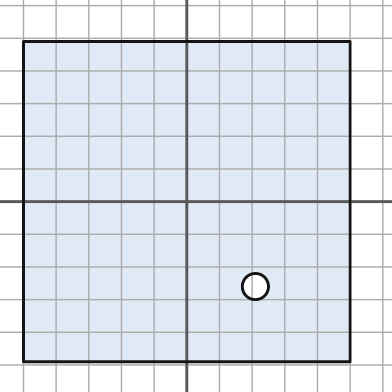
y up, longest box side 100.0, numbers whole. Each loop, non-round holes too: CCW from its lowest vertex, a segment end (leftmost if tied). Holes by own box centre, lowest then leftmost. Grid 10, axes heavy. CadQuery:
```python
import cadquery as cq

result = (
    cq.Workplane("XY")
    .moveTo(-50.0, -49.0)
    .lineTo(50.0, -49.0)
    .lineTo(50.0, 49.0)
    .lineTo(-50.0, 49.0)
    .close()
    .moveTo(21.0, -26.0)
    .circle(4.0)
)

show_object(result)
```